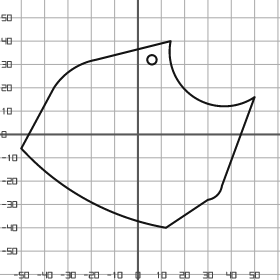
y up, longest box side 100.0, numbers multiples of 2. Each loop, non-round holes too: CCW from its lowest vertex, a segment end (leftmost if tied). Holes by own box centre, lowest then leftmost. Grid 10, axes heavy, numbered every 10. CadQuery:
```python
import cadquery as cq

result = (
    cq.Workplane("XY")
    .moveTo(12.0, -40.0)
    .lineTo(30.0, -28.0)
    .threePointArc((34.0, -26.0), (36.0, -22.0))
    .lineTo(50.0, 16.0)
    .threePointArc((24.0, 16.0), (14.0, 40.0))
    .lineTo(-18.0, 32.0)
    .threePointArc((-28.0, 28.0), (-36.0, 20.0))
    .lineTo(-50.0, -6.0)
    .threePointArc((-22.0, -28.0), (12.0, -40.0))
    .close()
    .moveTo(6.0, 32.0)
    .circle(2.0)
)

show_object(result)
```